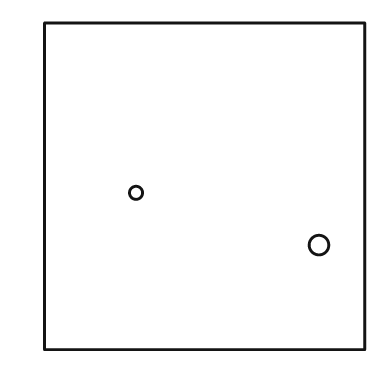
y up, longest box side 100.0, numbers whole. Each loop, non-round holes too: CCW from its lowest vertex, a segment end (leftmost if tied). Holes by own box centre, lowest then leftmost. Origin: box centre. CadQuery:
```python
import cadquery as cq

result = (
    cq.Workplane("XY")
    .moveTo(-49.0, -50.0)
    .lineTo(49.0, -50.0)
    .lineTo(49.0, 50.0)
    .lineTo(-49.0, 50.0)
    .close()
    .moveTo(35.0, -18.0)
    .circle(3.0)
    .moveTo(-21.0, -2.0)
    .circle(2.0)
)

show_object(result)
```